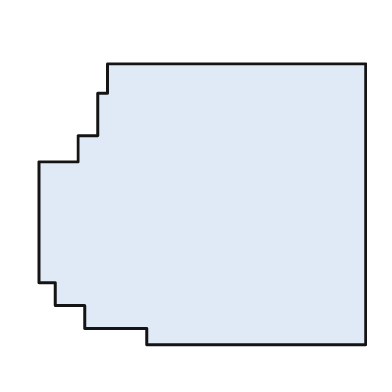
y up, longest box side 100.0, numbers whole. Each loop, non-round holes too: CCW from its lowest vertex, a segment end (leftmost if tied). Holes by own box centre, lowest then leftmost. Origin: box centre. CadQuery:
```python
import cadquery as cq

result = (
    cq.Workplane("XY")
    .moveTo(-17.0, -43.0)
    .lineTo(50.0, -43.0)
    .lineTo(50.0, 43.0)
    .lineTo(-29.0, 43.0)
    .lineTo(-29.0, 34.0)
    .lineTo(-32.0, 34.0)
    .lineTo(-32.0, 21.0)
    .lineTo(-38.0, 21.0)
    .lineTo(-38.0, 13.0)
    .lineTo(-50.0, 13.0)
    .lineTo(-50.0, -24.0)
    .lineTo(-45.0, -24.0)
    .lineTo(-45.0, -31.0)
    .lineTo(-36.0, -31.0)
    .lineTo(-36.0, -38.0)
    .lineTo(-17.0, -38.0)
    .close()
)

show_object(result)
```